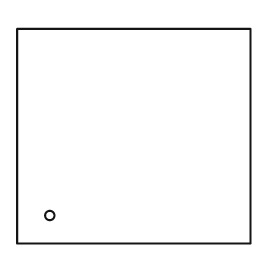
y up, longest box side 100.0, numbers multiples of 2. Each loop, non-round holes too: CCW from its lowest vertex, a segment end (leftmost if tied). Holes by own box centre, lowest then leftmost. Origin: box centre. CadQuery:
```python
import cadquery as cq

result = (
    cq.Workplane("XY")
    .moveTo(-50.0, -46.0)
    .lineTo(50.0, -46.0)
    .lineTo(50.0, 46.0)
    .lineTo(-50.0, 46.0)
    .close()
    .moveTo(-36.0, -34.0)
    .circle(2.0)
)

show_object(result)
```